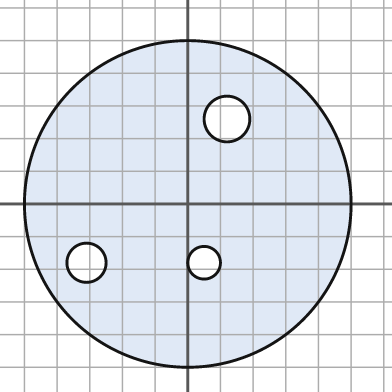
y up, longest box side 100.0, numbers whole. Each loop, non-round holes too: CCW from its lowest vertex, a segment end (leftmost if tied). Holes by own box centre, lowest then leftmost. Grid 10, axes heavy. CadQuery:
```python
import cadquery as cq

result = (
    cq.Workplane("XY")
    .moveTo(0.0, 0.0)
    .circle(50.0)
    .moveTo(-31.0, -18.0)
    .circle(6.0)
    .moveTo(5.0, -18.0)
    .circle(5.0)
    .moveTo(12.0, 26.0)
    .circle(7.0)
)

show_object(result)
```